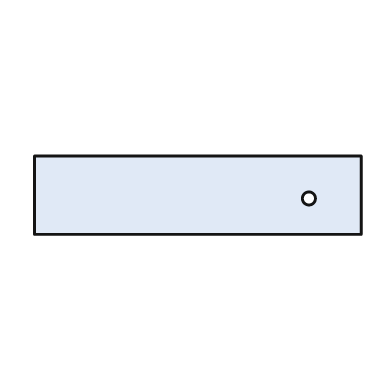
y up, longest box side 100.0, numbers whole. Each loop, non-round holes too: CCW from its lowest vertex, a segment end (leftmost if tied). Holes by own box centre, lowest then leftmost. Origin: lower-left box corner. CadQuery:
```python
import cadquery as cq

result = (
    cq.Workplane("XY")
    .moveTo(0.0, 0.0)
    .lineTo(100.0, 0.0)
    .lineTo(100.0, 24.0)
    .lineTo(0.0, 24.0)
    .close()
    .moveTo(84.0, 11.0)
    .circle(2.0)
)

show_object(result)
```